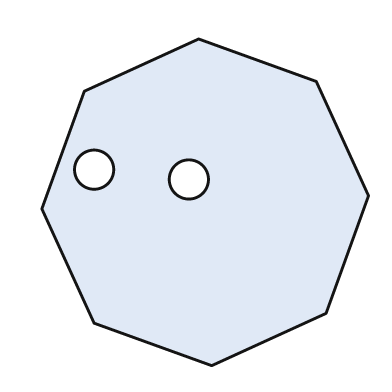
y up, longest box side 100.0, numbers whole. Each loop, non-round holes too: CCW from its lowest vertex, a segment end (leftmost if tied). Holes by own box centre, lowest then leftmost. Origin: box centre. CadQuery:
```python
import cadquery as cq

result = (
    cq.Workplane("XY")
    .moveTo(2.0, -50.0)
    .lineTo(37.0, -34.0)
    .lineTo(50.0, 2.0)
    .lineTo(34.0, 37.0)
    .lineTo(-2.0, 50.0)
    .lineTo(-37.0, 34.0)
    .lineTo(-50.0, -2.0)
    .lineTo(-34.0, -37.0)
    .close()
    .moveTo(-5.0, 7.0)
    .circle(6.0)
    .moveTo(-34.0, 10.0)
    .circle(6.0)
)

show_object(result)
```